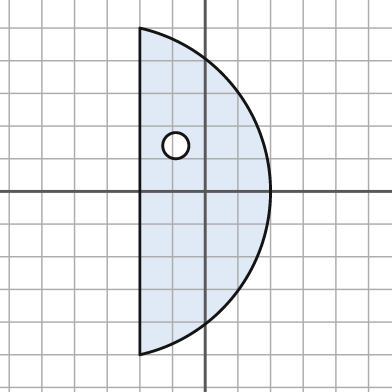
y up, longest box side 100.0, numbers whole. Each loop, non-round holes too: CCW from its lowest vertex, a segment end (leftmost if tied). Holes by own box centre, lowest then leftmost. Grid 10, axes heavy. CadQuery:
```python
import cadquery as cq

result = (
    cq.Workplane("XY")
    .moveTo(-20.0, -50.0)
    .threePointArc((20.0, 0.0), (-20.0, 50.0))
    .close()
    .moveTo(-9.0, 14.0)
    .circle(4.0)
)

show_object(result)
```